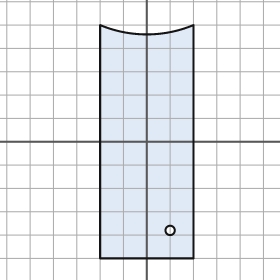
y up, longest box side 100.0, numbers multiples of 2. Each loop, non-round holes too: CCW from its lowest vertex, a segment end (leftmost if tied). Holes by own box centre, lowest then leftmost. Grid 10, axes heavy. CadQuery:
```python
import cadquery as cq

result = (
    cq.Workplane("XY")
    .moveTo(-20.0, -50.0)
    .lineTo(20.0, -50.0)
    .lineTo(20.0, 50.0)
    .threePointArc((0.0, 46.0), (-20.0, 50.0))
    .close()
    .moveTo(10.0, -38.0)
    .circle(2.0)
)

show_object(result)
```